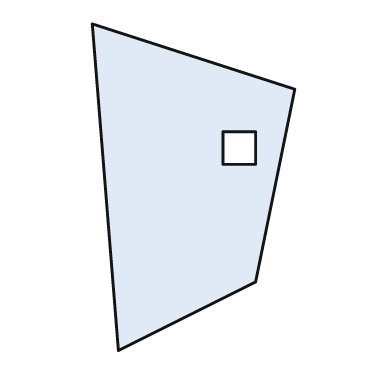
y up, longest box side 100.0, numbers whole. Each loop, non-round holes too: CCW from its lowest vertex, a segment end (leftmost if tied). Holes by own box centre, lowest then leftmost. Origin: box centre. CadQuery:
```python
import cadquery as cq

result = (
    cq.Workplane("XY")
    .moveTo(-23.0, -50.0)
    .lineTo(19.0, -29.0)
    .lineTo(31.0, 30.0)
    .lineTo(-31.0, 50.0)
    .close()
    .moveTo(9.0, 7.0)
    .lineTo(19.0, 7.0)
    .lineTo(19.0, 17.0)
    .lineTo(9.0, 17.0)
    .close()
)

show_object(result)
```